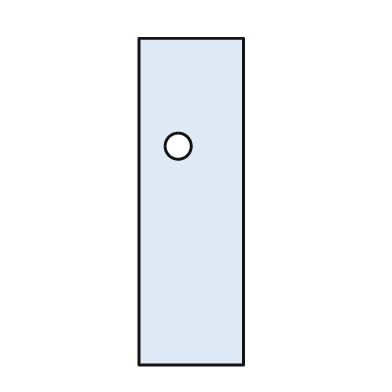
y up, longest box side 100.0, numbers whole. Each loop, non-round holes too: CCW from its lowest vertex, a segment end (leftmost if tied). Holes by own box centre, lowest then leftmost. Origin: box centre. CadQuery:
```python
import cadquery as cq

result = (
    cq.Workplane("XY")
    .moveTo(-16.0, -50.0)
    .lineTo(16.0, -50.0)
    .lineTo(16.0, 50.0)
    .lineTo(-16.0, 50.0)
    .close()
    .moveTo(-4.0, 17.0)
    .circle(4.0)
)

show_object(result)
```